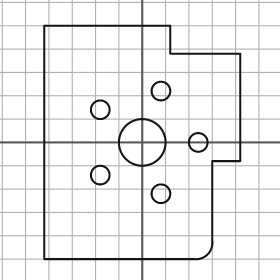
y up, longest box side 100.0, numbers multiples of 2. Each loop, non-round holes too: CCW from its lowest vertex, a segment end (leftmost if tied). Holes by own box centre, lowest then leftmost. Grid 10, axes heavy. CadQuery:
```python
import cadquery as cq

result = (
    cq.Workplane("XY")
    .moveTo(-42.0, -50.0)
    .lineTo(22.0, -50.0)
    .threePointArc((28.0, -48.0), (30.0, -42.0))
    .lineTo(30.0, -8.0)
    .lineTo(42.0, -8.0)
    .lineTo(42.0, 38.0)
    .lineTo(12.0, 38.0)
    .lineTo(12.0, 50.0)
    .lineTo(-42.0, 50.0)
    .close()
    .moveTo(8.0, -22.0)
    .circle(4.0)
    .moveTo(-18.0, -14.0)
    .circle(4.0)
    .moveTo(0.0, 0.0)
    .circle(10.0)
    .moveTo(24.0, 0.0)
    .circle(4.0)
    .moveTo(-18.0, 14.0)
    .circle(4.0)
    .moveTo(8.0, 22.0)
    .circle(4.0)
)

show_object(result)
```